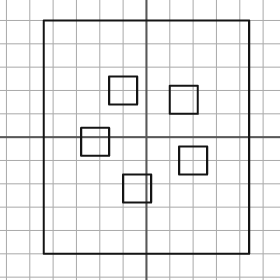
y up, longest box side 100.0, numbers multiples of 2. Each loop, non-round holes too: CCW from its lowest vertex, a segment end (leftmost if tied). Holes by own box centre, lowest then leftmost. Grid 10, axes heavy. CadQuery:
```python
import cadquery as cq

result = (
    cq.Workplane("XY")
    .moveTo(-44.0, -50.0)
    .lineTo(44.0, -50.0)
    .lineTo(44.0, 50.0)
    .lineTo(-44.0, 50.0)
    .close()
    .moveTo(-10.0, -28.0)
    .lineTo(2.0, -28.0)
    .lineTo(2.0, -16.0)
    .lineTo(-10.0, -16.0)
    .close()
    .moveTo(14.0, -16.0)
    .lineTo(26.0, -16.0)
    .lineTo(26.0, -4.0)
    .lineTo(14.0, -4.0)
    .close()
    .moveTo(-28.0, -8.0)
    .lineTo(-16.0, -8.0)
    .lineTo(-16.0, 4.0)
    .lineTo(-28.0, 4.0)
    .close()
    .moveTo(10.0, 10.0)
    .lineTo(22.0, 10.0)
    .lineTo(22.0, 22.0)
    .lineTo(10.0, 22.0)
    .close()
    .moveTo(-16.0, 14.0)
    .lineTo(-4.0, 14.0)
    .lineTo(-4.0, 26.0)
    .lineTo(-16.0, 26.0)
    .close()
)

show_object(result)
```